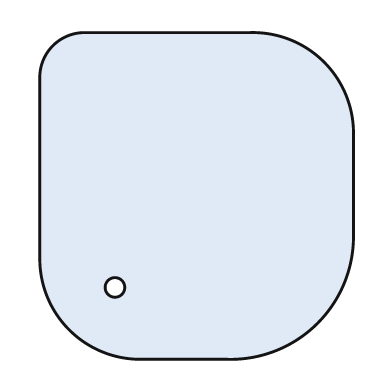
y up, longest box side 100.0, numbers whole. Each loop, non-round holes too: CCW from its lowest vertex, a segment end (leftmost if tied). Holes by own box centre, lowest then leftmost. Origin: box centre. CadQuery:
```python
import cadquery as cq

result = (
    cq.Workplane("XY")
    .moveTo(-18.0, -50.0)
    .lineTo(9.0, -50.0)
    .threePointArc((37.0, -39.0), (48.0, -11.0))
    .lineTo(48.0, 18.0)
    .threePointArc((39.0, 41.0), (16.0, 50.0))
    .lineTo(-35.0, 50.0)
    .threePointArc((-44.0, 46.0), (-48.0, 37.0))
    .lineTo(-48.0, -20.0)
    .threePointArc((-39.0, -41.0), (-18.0, -50.0))
    .close()
    .moveTo(-25.0, -28.0)
    .circle(3.0)
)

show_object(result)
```